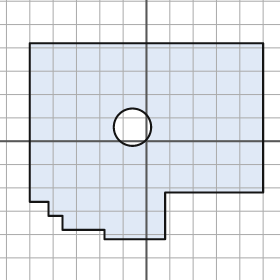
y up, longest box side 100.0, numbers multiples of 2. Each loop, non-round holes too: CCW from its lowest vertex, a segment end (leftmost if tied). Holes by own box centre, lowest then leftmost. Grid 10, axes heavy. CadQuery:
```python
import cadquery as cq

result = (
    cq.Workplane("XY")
    .moveTo(-18.0, -42.0)
    .lineTo(8.0, -42.0)
    .lineTo(8.0, -22.0)
    .lineTo(50.0, -22.0)
    .lineTo(50.0, 42.0)
    .lineTo(-50.0, 42.0)
    .lineTo(-50.0, -26.0)
    .lineTo(-42.0, -26.0)
    .lineTo(-42.0, -32.0)
    .lineTo(-36.0, -32.0)
    .lineTo(-36.0, -38.0)
    .lineTo(-18.0, -38.0)
    .close()
    .moveTo(-6.0, 6.0)
    .circle(8.0)
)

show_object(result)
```